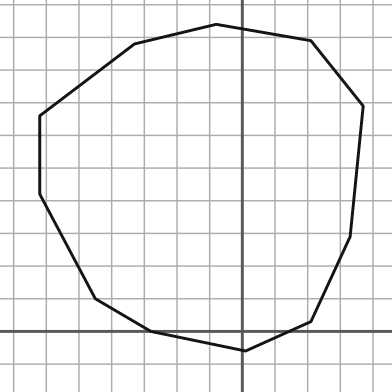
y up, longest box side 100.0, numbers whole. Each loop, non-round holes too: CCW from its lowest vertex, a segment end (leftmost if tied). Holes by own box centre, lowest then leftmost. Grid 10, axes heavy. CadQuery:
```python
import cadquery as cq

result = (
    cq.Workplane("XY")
    .moveTo(1.0, -6.0)
    .lineTo(21.0, 3.0)
    .lineTo(33.0, 29.0)
    .lineTo(37.0, 69.0)
    .lineTo(21.0, 89.0)
    .lineTo(-8.0, 94.0)
    .lineTo(-33.0, 88.0)
    .lineTo(-62.0, 66.0)
    .lineTo(-62.0, 42.0)
    .lineTo(-45.0, 10.0)
    .lineTo(-28.0, 0.0)
    .close()
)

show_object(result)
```